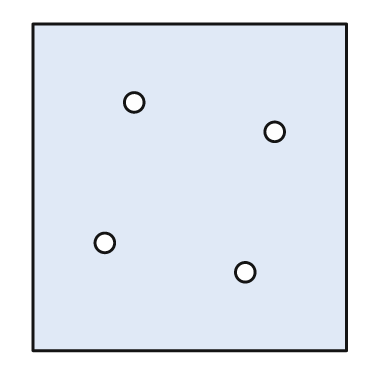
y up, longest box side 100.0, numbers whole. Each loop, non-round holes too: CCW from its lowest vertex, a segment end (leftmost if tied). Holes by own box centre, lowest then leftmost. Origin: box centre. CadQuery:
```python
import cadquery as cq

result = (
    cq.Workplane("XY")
    .moveTo(-48.0, -50.0)
    .lineTo(48.0, -50.0)
    .lineTo(48.0, 50.0)
    .lineTo(-48.0, 50.0)
    .close()
    .moveTo(17.0, -26.0)
    .circle(3.0)
    .moveTo(-26.0, -17.0)
    .circle(3.0)
    .moveTo(26.0, 17.0)
    .circle(3.0)
    .moveTo(-17.0, 26.0)
    .circle(3.0)
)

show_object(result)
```